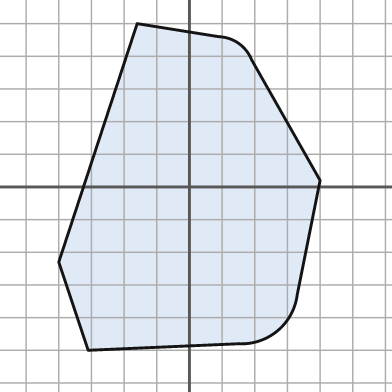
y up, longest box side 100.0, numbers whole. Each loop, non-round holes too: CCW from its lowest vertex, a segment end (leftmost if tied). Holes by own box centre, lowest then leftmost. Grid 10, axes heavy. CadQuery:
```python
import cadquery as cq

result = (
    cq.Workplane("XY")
    .moveTo(-31.0, -50.0)
    .lineTo(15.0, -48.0)
    .threePointArc((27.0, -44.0), (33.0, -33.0))
    .lineTo(40.0, 2.0)
    .lineTo(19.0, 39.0)
    .threePointArc((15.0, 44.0), (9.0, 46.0))
    .lineTo(-16.0, 50.0)
    .lineTo(-40.0, -23.0)
    .close()
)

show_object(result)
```